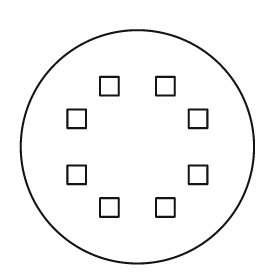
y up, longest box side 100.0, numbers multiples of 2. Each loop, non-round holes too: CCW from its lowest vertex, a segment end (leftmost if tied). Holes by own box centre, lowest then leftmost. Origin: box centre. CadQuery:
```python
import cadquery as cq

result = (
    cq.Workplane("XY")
    .moveTo(0.0, 0.0)
    .circle(50.0)
    .moveTo(-16.0, -30.0)
    .lineTo(-8.0, -30.0)
    .lineTo(-8.0, -22.0)
    .lineTo(-16.0, -22.0)
    .close()
    .moveTo(8.0, -30.0)
    .lineTo(16.0, -30.0)
    .lineTo(16.0, -22.0)
    .lineTo(8.0, -22.0)
    .close()
    .moveTo(-30.0, -16.0)
    .lineTo(-22.0, -16.0)
    .lineTo(-22.0, -8.0)
    .lineTo(-30.0, -8.0)
    .close()
    .moveTo(22.0, -16.0)
    .lineTo(30.0, -16.0)
    .lineTo(30.0, -8.0)
    .lineTo(22.0, -8.0)
    .close()
    .moveTo(-30.0, 8.0)
    .lineTo(-22.0, 8.0)
    .lineTo(-22.0, 16.0)
    .lineTo(-30.0, 16.0)
    .close()
    .moveTo(22.0, 8.0)
    .lineTo(30.0, 8.0)
    .lineTo(30.0, 16.0)
    .lineTo(22.0, 16.0)
    .close()
    .moveTo(-16.0, 22.0)
    .lineTo(-8.0, 22.0)
    .lineTo(-8.0, 30.0)
    .lineTo(-16.0, 30.0)
    .close()
    .moveTo(8.0, 22.0)
    .lineTo(16.0, 22.0)
    .lineTo(16.0, 30.0)
    .lineTo(8.0, 30.0)
    .close()
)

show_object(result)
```